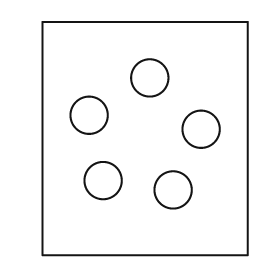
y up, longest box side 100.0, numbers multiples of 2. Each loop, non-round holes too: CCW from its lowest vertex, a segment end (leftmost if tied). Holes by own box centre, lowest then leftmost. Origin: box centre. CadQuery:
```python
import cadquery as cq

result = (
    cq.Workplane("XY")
    .moveTo(-44.0, -50.0)
    .lineTo(44.0, -50.0)
    .lineTo(44.0, 50.0)
    .lineTo(-44.0, 50.0)
    .close()
    .moveTo(12.0, -22.0)
    .circle(8.0)
    .moveTo(-18.0, -18.0)
    .circle(8.0)
    .moveTo(24.0, 4.0)
    .circle(8.0)
    .moveTo(-24.0, 10.0)
    .circle(8.0)
    .moveTo(2.0, 26.0)
    .circle(8.0)
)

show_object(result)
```